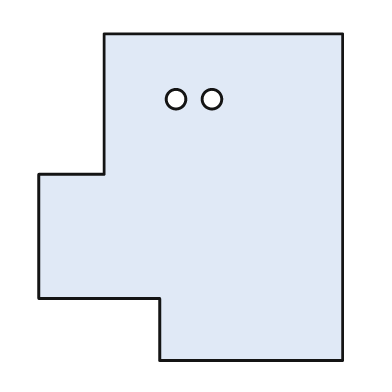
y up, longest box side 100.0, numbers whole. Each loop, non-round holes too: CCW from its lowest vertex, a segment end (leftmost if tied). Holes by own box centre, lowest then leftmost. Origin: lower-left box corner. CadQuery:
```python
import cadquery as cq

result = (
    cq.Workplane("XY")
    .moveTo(37.0, 0.0)
    .lineTo(93.0, 0.0)
    .lineTo(93.0, 100.0)
    .lineTo(20.0, 100.0)
    .lineTo(20.0, 57.0)
    .lineTo(0.0, 57.0)
    .lineTo(0.0, 19.0)
    .lineTo(37.0, 19.0)
    .close()
    .moveTo(42.0, 80.0)
    .circle(3.0)
    .moveTo(53.0, 80.0)
    .circle(3.0)
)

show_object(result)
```